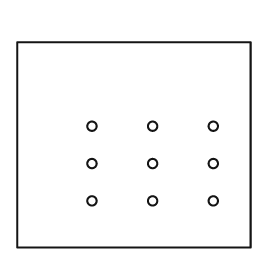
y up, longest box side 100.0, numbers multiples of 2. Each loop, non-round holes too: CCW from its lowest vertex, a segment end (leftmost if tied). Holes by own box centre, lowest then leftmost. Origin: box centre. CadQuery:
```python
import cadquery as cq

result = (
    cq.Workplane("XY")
    .moveTo(-50.0, -44.0)
    .lineTo(50.0, -44.0)
    .lineTo(50.0, 44.0)
    .lineTo(-50.0, 44.0)
    .close()
    .moveTo(-18.0, -24.0)
    .circle(2.0)
    .moveTo(8.0, -24.0)
    .circle(2.0)
    .moveTo(34.0, -24.0)
    .circle(2.0)
    .moveTo(-18.0, -8.0)
    .circle(2.0)
    .moveTo(8.0, -8.0)
    .circle(2.0)
    .moveTo(34.0, -8.0)
    .circle(2.0)
    .moveTo(-18.0, 8.0)
    .circle(2.0)
    .moveTo(8.0, 8.0)
    .circle(2.0)
    .moveTo(34.0, 8.0)
    .circle(2.0)
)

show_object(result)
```